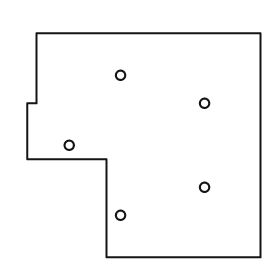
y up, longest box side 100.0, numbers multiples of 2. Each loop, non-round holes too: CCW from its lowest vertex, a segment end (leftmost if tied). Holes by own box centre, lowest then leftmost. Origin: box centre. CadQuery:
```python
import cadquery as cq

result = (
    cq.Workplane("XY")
    .moveTo(-16.0, -48.0)
    .lineTo(50.0, -48.0)
    .lineTo(50.0, 48.0)
    .lineTo(-46.0, 48.0)
    .lineTo(-46.0, 18.0)
    .lineTo(-50.0, 18.0)
    .lineTo(-50.0, -6.0)
    .lineTo(-16.0, -6.0)
    .close()
    .moveTo(-10.0, -30.0)
    .circle(2.0)
    .moveTo(26.0, -18.0)
    .circle(2.0)
    .moveTo(-32.0, 0.0)
    .circle(2.0)
    .moveTo(26.0, 18.0)
    .circle(2.0)
    .moveTo(-10.0, 30.0)
    .circle(2.0)
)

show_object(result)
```